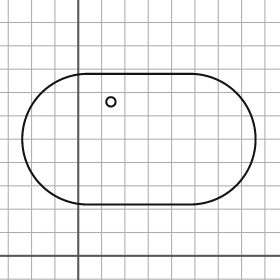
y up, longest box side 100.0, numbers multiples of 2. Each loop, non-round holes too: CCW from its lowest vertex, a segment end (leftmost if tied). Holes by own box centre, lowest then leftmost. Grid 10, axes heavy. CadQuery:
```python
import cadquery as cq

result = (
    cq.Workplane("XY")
    .moveTo(4.0, 22.0)
    .lineTo(48.0, 22.0)
    .threePointArc((76.0, 50.0), (48.0, 78.0))
    .lineTo(4.0, 78.0)
    .threePointArc((-24.0, 50.0), (4.0, 22.0))
    .close()
    .moveTo(14.0, 66.0)
    .circle(2.0)
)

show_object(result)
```